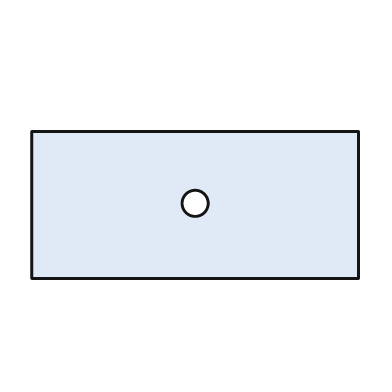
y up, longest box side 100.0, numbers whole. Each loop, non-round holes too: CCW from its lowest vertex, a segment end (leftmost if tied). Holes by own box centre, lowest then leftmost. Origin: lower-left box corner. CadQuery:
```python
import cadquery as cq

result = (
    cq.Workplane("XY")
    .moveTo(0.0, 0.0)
    .lineTo(100.0, 0.0)
    .lineTo(100.0, 45.0)
    .lineTo(0.0, 45.0)
    .close()
    .moveTo(50.0, 23.0)
    .circle(4.0)
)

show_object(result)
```